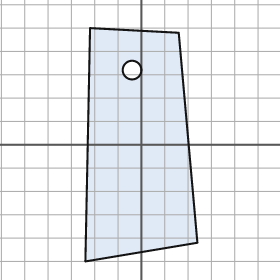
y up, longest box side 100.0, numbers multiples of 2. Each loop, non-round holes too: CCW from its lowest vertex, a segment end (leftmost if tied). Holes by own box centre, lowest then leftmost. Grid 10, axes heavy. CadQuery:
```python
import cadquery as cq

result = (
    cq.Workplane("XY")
    .moveTo(-24.0, -50.0)
    .lineTo(24.0, -42.0)
    .lineTo(16.0, 48.0)
    .lineTo(-22.0, 50.0)
    .close()
    .moveTo(-4.0, 32.0)
    .circle(4.0)
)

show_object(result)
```